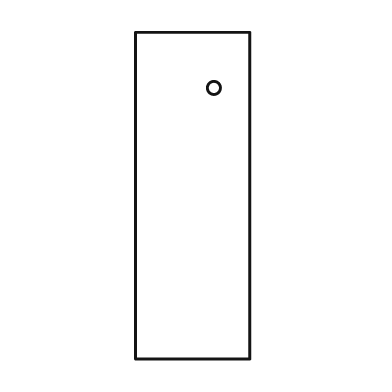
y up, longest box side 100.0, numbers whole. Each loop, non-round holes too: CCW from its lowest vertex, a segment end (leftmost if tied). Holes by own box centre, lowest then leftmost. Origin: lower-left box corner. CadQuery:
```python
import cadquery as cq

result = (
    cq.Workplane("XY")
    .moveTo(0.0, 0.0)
    .lineTo(35.0, 0.0)
    .lineTo(35.0, 100.0)
    .lineTo(0.0, 100.0)
    .close()
    .moveTo(24.0, 83.0)
    .circle(2.0)
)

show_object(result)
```